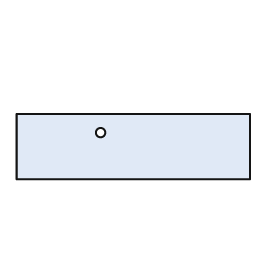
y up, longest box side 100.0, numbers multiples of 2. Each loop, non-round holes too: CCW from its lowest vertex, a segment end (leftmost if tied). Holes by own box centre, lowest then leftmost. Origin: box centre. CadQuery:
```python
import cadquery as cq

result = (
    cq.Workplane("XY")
    .moveTo(-50.0, -14.0)
    .lineTo(50.0, -14.0)
    .lineTo(50.0, 14.0)
    .lineTo(-50.0, 14.0)
    .close()
    .moveTo(-14.0, 6.0)
    .circle(2.0)
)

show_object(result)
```